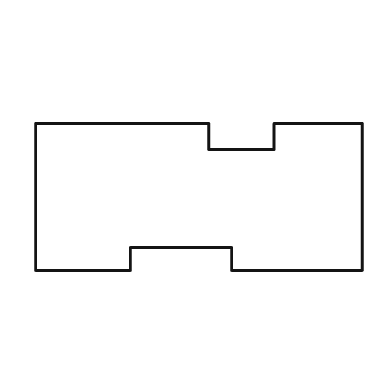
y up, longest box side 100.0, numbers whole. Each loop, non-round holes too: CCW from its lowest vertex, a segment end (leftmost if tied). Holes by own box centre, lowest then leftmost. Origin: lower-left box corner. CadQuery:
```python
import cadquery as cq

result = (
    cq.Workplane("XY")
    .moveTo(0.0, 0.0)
    .lineTo(29.0, 0.0)
    .lineTo(29.0, 7.0)
    .lineTo(60.0, 7.0)
    .lineTo(60.0, 0.0)
    .lineTo(100.0, 0.0)
    .lineTo(100.0, 45.0)
    .lineTo(73.0, 45.0)
    .lineTo(73.0, 37.0)
    .lineTo(53.0, 37.0)
    .lineTo(53.0, 45.0)
    .lineTo(0.0, 45.0)
    .close()
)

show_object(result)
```